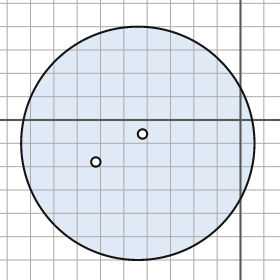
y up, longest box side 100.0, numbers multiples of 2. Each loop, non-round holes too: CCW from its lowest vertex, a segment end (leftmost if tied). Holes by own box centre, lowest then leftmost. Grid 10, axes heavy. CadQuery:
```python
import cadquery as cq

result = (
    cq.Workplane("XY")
    .moveTo(-44.0, -10.0)
    .circle(50.0)
    .moveTo(-62.0, -18.0)
    .circle(2.0)
    .moveTo(-42.0, -6.0)
    .circle(2.0)
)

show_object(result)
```